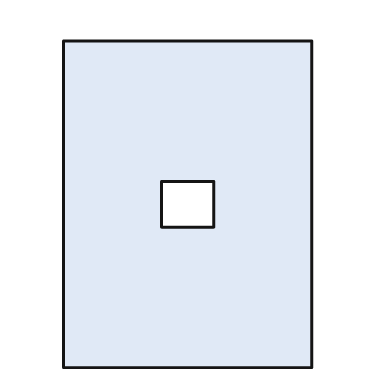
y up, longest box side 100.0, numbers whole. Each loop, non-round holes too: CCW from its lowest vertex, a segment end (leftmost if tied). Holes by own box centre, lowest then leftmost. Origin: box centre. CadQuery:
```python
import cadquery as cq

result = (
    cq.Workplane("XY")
    .moveTo(-38.0, -50.0)
    .lineTo(38.0, -50.0)
    .lineTo(38.0, 50.0)
    .lineTo(-38.0, 50.0)
    .close()
    .moveTo(-8.0, -7.0)
    .lineTo(8.0, -7.0)
    .lineTo(8.0, 7.0)
    .lineTo(-8.0, 7.0)
    .close()
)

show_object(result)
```